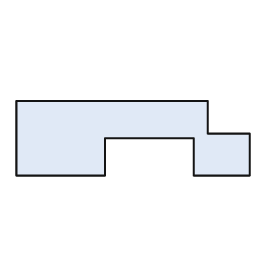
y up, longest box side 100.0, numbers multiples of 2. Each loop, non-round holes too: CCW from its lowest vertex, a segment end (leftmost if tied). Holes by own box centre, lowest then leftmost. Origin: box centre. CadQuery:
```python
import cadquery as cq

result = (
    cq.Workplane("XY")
    .moveTo(-50.0, -16.0)
    .lineTo(-12.0, -16.0)
    .lineTo(-12.0, 0.0)
    .lineTo(26.0, 0.0)
    .lineTo(26.0, -16.0)
    .lineTo(50.0, -16.0)
    .lineTo(50.0, 2.0)
    .lineTo(32.0, 2.0)
    .lineTo(32.0, 16.0)
    .lineTo(-50.0, 16.0)
    .close()
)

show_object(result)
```